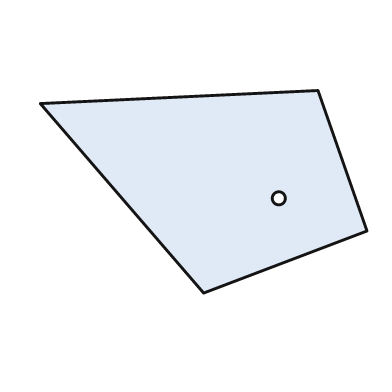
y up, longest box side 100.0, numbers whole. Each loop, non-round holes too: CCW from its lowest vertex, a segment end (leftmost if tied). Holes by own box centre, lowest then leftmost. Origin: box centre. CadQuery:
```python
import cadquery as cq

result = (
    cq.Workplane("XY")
    .moveTo(0.0, -31.0)
    .lineTo(50.0, -12.0)
    .lineTo(35.0, 31.0)
    .lineTo(-50.0, 27.0)
    .close()
    .moveTo(23.0, -2.0)
    .circle(2.0)
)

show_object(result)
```